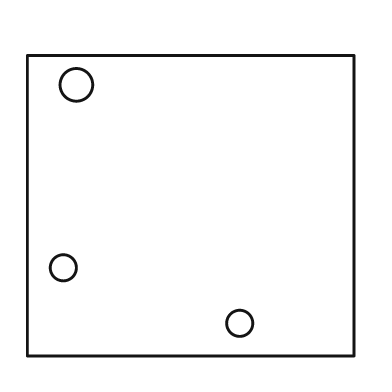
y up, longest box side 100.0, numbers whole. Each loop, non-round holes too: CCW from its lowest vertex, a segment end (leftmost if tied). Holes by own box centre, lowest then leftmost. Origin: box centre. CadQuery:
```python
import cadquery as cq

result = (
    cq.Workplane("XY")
    .moveTo(-50.0, -46.0)
    .lineTo(50.0, -46.0)
    .lineTo(50.0, 46.0)
    .lineTo(-50.0, 46.0)
    .close()
    .moveTo(15.0, -36.0)
    .circle(4.0)
    .moveTo(-39.0, -19.0)
    .circle(4.0)
    .moveTo(-35.0, 37.0)
    .circle(5.0)
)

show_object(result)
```